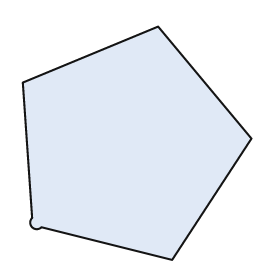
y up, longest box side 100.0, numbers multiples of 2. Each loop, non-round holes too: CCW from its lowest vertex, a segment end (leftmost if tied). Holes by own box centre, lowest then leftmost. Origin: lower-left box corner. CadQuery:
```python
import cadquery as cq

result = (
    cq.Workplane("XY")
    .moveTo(64.0, 0.0)
    .lineTo(98.0, 52.0)
    .lineTo(58.0, 100.0)
    .lineTo(0.0, 76.0)
    .lineTo(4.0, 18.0)
    .threePointArc((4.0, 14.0), (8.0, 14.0))
    .close()
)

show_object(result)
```